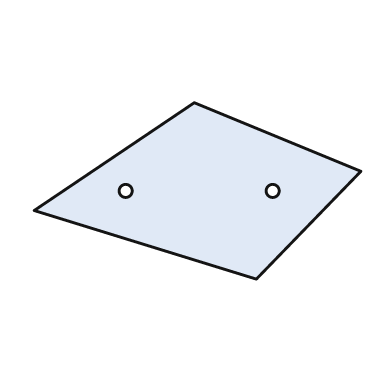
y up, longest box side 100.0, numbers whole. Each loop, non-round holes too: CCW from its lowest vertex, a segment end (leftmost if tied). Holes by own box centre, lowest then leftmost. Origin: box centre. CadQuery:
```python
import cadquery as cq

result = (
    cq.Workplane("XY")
    .moveTo(18.0, -27.0)
    .lineTo(50.0, 6.0)
    .lineTo(-1.0, 27.0)
    .lineTo(-50.0, -6.0)
    .close()
    .moveTo(-22.0, 0.0)
    .circle(2.0)
    .moveTo(23.0, 0.0)
    .circle(2.0)
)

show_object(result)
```